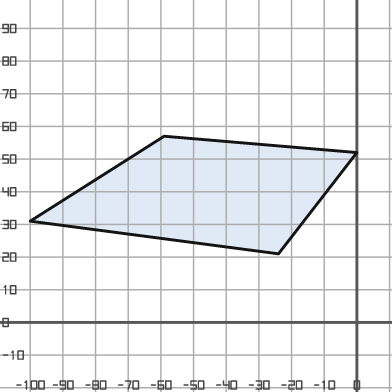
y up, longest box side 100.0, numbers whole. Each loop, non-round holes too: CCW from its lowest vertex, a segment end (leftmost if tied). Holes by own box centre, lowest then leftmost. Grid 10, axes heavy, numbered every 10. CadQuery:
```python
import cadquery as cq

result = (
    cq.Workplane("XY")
    .moveTo(-24.0, 21.0)
    .lineTo(0.0, 52.0)
    .lineTo(-59.0, 57.0)
    .lineTo(-100.0, 31.0)
    .close()
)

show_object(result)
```